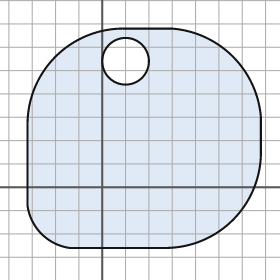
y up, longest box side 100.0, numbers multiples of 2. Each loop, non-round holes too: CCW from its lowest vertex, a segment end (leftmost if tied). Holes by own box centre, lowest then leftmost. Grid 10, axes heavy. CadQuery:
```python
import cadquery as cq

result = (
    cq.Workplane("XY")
    .moveTo(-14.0, -26.0)
    .lineTo(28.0, -26.0)
    .threePointArc((56.0, -14.0), (68.0, 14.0))
    .lineTo(68.0, 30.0)
    .threePointArc((56.0, 56.0), (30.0, 68.0))
    .lineTo(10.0, 68.0)
    .threePointArc((-20.0, 56.0), (-32.0, 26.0))
    .lineTo(-32.0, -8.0)
    .threePointArc((-26.0, -20.0), (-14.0, -26.0))
    .close()
    .moveTo(10.0, 54.0)
    .circle(10.0)
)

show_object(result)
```